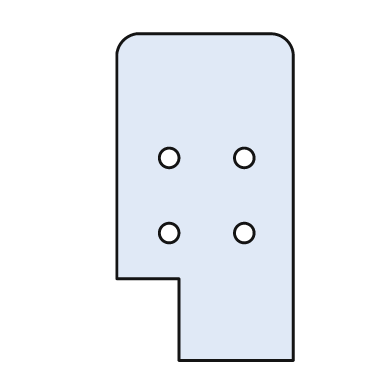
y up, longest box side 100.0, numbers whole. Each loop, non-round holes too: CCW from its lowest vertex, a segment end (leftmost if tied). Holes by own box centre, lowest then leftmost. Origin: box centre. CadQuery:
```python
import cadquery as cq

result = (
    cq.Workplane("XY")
    .moveTo(-8.0, -50.0)
    .lineTo(27.0, -50.0)
    .lineTo(27.0, 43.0)
    .threePointArc((25.0, 48.0), (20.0, 50.0))
    .lineTo(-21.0, 50.0)
    .threePointArc((-25.0, 48.0), (-27.0, 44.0))
    .lineTo(-27.0, -25.0)
    .lineTo(-8.0, -25.0)
    .close()
    .moveTo(-11.0, -11.0)
    .circle(3.0)
    .moveTo(12.0, -11.0)
    .circle(3.0)
    .moveTo(-11.0, 12.0)
    .circle(3.0)
    .moveTo(12.0, 12.0)
    .circle(3.0)
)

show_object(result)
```